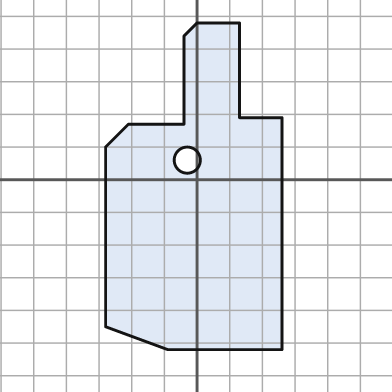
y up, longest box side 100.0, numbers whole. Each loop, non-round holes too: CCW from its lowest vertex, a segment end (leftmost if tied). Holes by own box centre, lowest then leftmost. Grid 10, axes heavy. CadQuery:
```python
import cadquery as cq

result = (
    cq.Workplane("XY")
    .moveTo(-9.0, -52.0)
    .lineTo(26.0, -52.0)
    .lineTo(26.0, 19.0)
    .lineTo(13.0, 19.0)
    .lineTo(13.0, 48.0)
    .lineTo(0.0, 48.0)
    .lineTo(-4.0, 44.0)
    .lineTo(-4.0, 17.0)
    .lineTo(-21.0, 17.0)
    .lineTo(-28.0, 10.0)
    .lineTo(-28.0, -45.0)
    .close()
    .moveTo(-3.0, 6.0)
    .circle(4.0)
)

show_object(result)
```